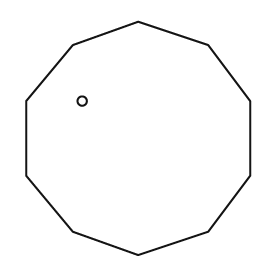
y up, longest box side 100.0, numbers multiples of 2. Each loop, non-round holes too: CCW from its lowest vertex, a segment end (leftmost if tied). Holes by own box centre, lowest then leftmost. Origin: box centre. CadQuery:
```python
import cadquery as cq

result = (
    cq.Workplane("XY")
    .moveTo(0.0, -50.0)
    .lineTo(30.0, -40.0)
    .lineTo(48.0, -16.0)
    .lineTo(48.0, 16.0)
    .lineTo(30.0, 40.0)
    .lineTo(0.0, 50.0)
    .lineTo(-28.0, 40.0)
    .lineTo(-48.0, 16.0)
    .lineTo(-48.0, -16.0)
    .lineTo(-28.0, -40.0)
    .close()
    .moveTo(-24.0, 16.0)
    .circle(2.0)
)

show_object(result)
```